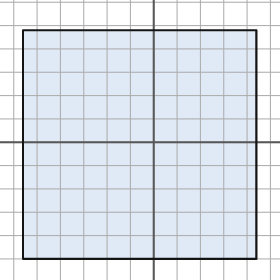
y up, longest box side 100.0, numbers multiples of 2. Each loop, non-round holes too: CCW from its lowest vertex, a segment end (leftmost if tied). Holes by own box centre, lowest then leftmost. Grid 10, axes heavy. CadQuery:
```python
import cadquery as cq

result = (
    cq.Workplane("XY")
    .moveTo(-56.0, -50.0)
    .lineTo(44.0, -50.0)
    .lineTo(44.0, 48.0)
    .lineTo(-56.0, 48.0)
    .close()
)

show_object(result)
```